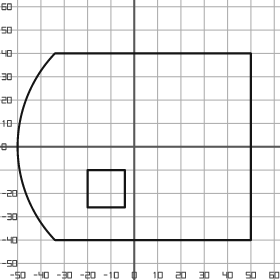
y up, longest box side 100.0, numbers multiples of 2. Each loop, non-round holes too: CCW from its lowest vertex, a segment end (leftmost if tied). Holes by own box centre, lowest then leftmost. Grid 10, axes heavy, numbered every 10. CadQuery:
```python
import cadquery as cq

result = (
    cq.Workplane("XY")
    .moveTo(-34.0, -40.0)
    .lineTo(50.0, -40.0)
    .lineTo(50.0, 40.0)
    .lineTo(-34.0, 40.0)
    .threePointArc((-50.0, 0.0), (-34.0, -40.0))
    .close()
    .moveTo(-20.0, -26.0)
    .lineTo(-4.0, -26.0)
    .lineTo(-4.0, -10.0)
    .lineTo(-20.0, -10.0)
    .close()
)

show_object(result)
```